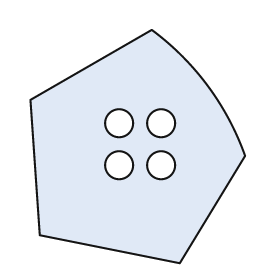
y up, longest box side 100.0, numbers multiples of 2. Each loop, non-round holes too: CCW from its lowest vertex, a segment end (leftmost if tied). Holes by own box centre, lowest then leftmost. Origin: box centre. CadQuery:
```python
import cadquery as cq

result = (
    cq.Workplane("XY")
    .moveTo(18.0, -50.0)
    .lineTo(46.0, -4.0)
    .threePointArc((30.0, 26.0), (6.0, 50.0))
    .lineTo(-46.0, 20.0)
    .lineTo(-42.0, -38.0)
    .close()
    .moveTo(-8.0, -8.0)
    .circle(6.0)
    .moveTo(10.0, -8.0)
    .circle(6.0)
    .moveTo(-8.0, 10.0)
    .circle(6.0)
    .moveTo(10.0, 10.0)
    .circle(6.0)
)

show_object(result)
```